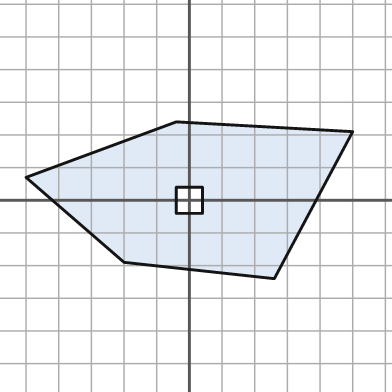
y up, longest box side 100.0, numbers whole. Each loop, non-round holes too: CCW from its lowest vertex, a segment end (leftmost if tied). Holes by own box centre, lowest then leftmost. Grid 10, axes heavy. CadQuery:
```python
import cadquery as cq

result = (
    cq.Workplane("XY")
    .moveTo(26.0, -24.0)
    .lineTo(50.0, 21.0)
    .lineTo(-4.0, 24.0)
    .lineTo(-50.0, 7.0)
    .lineTo(-20.0, -19.0)
    .close()
    .moveTo(-4.0, -4.0)
    .lineTo(4.0, -4.0)
    .lineTo(4.0, 4.0)
    .lineTo(-4.0, 4.0)
    .close()
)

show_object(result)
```